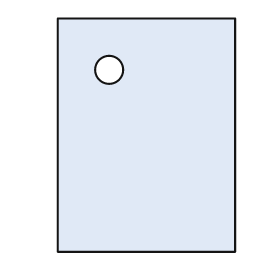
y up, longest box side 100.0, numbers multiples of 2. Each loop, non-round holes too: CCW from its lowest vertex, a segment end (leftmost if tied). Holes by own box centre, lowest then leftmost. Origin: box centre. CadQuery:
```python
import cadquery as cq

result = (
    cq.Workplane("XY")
    .moveTo(-38.0, -50.0)
    .lineTo(38.0, -50.0)
    .lineTo(38.0, 50.0)
    .lineTo(-38.0, 50.0)
    .close()
    .moveTo(-16.0, 28.0)
    .circle(6.0)
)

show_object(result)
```